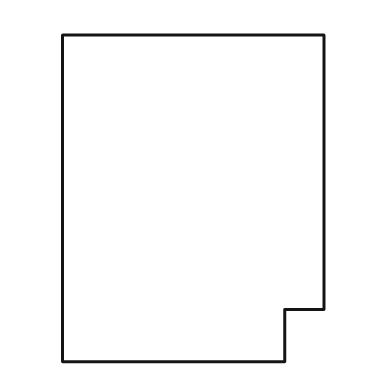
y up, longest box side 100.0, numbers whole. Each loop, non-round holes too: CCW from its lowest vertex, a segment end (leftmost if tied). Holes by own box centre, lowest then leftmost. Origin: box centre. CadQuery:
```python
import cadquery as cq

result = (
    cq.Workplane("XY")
    .moveTo(-40.0, -50.0)
    .lineTo(28.0, -50.0)
    .lineTo(28.0, -34.0)
    .lineTo(40.0, -34.0)
    .lineTo(40.0, 50.0)
    .lineTo(-40.0, 50.0)
    .close()
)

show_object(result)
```